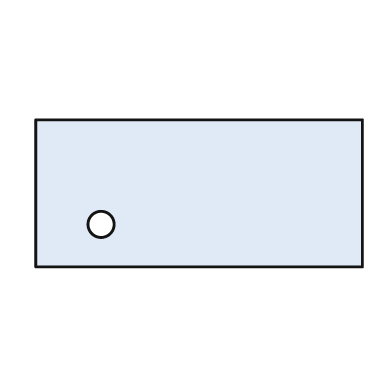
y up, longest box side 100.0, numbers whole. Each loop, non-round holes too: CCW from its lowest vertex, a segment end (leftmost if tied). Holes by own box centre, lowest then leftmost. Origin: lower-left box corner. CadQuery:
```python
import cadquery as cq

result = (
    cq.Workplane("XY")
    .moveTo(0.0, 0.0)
    .lineTo(100.0, 0.0)
    .lineTo(100.0, 45.0)
    .lineTo(0.0, 45.0)
    .close()
    .moveTo(20.0, 13.0)
    .circle(4.0)
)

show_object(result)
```